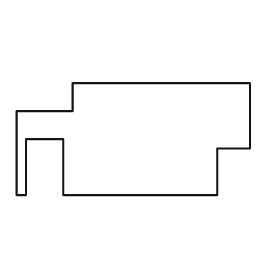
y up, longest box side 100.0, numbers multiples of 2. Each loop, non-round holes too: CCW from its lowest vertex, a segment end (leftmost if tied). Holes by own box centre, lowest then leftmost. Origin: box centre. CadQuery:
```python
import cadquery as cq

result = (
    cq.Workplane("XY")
    .moveTo(-50.0, -24.0)
    .lineTo(-46.0, -24.0)
    .lineTo(-46.0, 0.0)
    .lineTo(-30.0, 0.0)
    .lineTo(-30.0, -24.0)
    .lineTo(36.0, -24.0)
    .lineTo(36.0, -4.0)
    .lineTo(50.0, -4.0)
    .lineTo(50.0, 24.0)
    .lineTo(-26.0, 24.0)
    .lineTo(-26.0, 12.0)
    .lineTo(-50.0, 12.0)
    .close()
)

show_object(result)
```